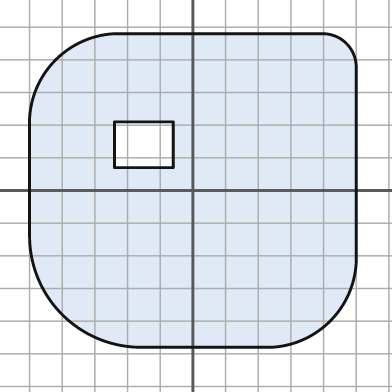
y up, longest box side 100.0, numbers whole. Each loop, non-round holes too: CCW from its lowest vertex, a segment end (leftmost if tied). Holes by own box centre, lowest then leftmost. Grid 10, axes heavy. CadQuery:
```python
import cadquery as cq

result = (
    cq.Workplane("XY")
    .moveTo(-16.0, -48.0)
    .lineTo(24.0, -48.0)
    .threePointArc((42.0, -40.0), (50.0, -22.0))
    .lineTo(50.0, 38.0)
    .threePointArc((47.0, 45.0), (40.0, 48.0))
    .lineTo(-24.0, 48.0)
    .threePointArc((-42.0, 40.0), (-50.0, 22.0))
    .lineTo(-50.0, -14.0)
    .threePointArc((-40.0, -38.0), (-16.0, -48.0))
    .close()
    .moveTo(-24.0, 7.0)
    .lineTo(-6.0, 7.0)
    .lineTo(-6.0, 21.0)
    .lineTo(-24.0, 21.0)
    .close()
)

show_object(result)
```